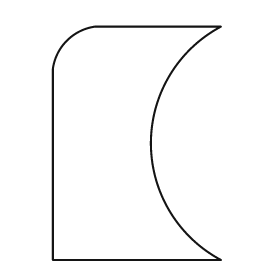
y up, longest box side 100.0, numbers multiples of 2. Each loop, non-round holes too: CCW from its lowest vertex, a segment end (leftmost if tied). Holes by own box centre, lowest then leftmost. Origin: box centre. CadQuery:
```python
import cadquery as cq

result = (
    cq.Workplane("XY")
    .moveTo(-36.0, -50.0)
    .lineTo(36.0, -50.0)
    .threePointArc((6.0, 0.0), (36.0, 50.0))
    .lineTo(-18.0, 50.0)
    .threePointArc((-30.0, 44.0), (-36.0, 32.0))
    .close()
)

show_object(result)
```